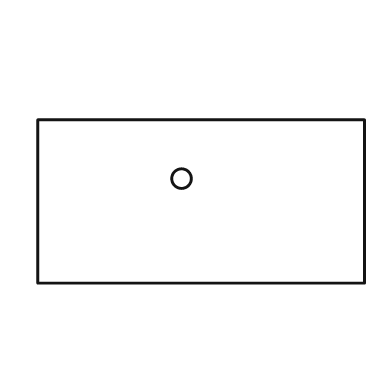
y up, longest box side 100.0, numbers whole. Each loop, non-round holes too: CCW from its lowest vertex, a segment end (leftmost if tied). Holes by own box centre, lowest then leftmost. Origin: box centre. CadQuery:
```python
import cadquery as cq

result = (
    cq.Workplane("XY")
    .moveTo(-50.0, -25.0)
    .lineTo(50.0, -25.0)
    .lineTo(50.0, 25.0)
    .lineTo(-50.0, 25.0)
    .close()
    .moveTo(-6.0, 7.0)
    .circle(3.0)
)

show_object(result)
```